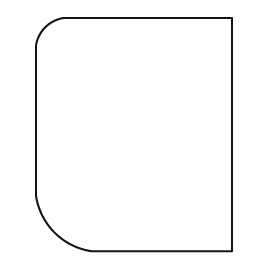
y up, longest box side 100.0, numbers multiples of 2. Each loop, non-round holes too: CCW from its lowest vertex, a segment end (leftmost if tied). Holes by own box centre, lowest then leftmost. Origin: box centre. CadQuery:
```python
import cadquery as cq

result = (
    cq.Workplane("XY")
    .moveTo(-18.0, -50.0)
    .lineTo(42.0, -50.0)
    .lineTo(42.0, 50.0)
    .lineTo(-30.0, 50.0)
    .threePointArc((-38.0, 46.0), (-42.0, 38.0))
    .lineTo(-42.0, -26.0)
    .threePointArc((-34.0, -42.0), (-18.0, -50.0))
    .close()
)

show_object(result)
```